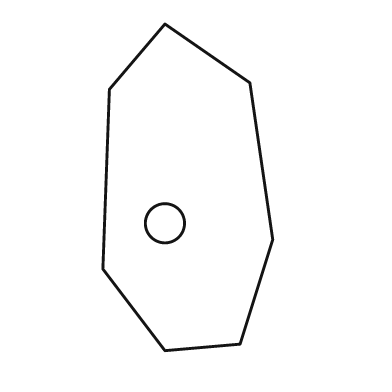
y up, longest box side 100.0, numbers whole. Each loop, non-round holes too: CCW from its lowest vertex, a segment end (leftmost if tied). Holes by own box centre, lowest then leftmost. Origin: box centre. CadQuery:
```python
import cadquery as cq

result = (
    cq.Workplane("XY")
    .moveTo(-7.0, -50.0)
    .lineTo(16.0, -48.0)
    .lineTo(26.0, -16.0)
    .lineTo(19.0, 32.0)
    .lineTo(-7.0, 50.0)
    .lineTo(-24.0, 30.0)
    .lineTo(-26.0, -25.0)
    .close()
    .moveTo(-7.0, -11.0)
    .circle(6.0)
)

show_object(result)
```